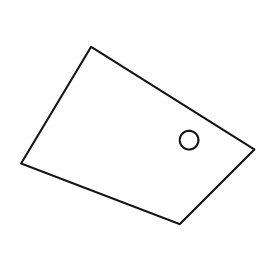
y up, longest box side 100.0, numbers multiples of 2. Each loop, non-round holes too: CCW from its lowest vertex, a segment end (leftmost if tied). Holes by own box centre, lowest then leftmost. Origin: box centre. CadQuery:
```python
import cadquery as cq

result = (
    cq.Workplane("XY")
    .moveTo(18.0, -38.0)
    .lineTo(50.0, -6.0)
    .lineTo(-20.0, 38.0)
    .lineTo(-50.0, -12.0)
    .close()
    .moveTo(22.0, -2.0)
    .circle(4.0)
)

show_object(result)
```